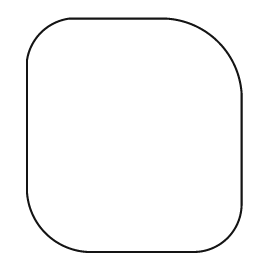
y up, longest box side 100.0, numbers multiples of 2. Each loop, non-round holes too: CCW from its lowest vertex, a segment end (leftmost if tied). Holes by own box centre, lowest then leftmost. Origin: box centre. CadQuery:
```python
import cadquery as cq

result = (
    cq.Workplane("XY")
    .moveTo(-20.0, -50.0)
    .lineTo(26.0, -50.0)
    .threePointArc((40.0, -44.0), (46.0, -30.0))
    .lineTo(46.0, 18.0)
    .threePointArc((36.0, 40.0), (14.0, 50.0))
    .lineTo(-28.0, 50.0)
    .threePointArc((-40.0, 44.0), (-46.0, 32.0))
    .lineTo(-46.0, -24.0)
    .threePointArc((-38.0, -42.0), (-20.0, -50.0))
    .close()
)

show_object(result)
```